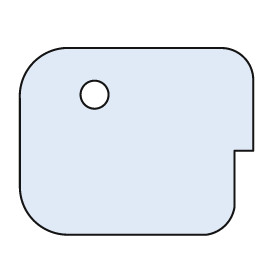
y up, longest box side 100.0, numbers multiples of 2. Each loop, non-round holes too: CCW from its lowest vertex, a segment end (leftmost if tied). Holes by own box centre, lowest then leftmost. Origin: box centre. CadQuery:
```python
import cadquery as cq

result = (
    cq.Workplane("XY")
    .moveTo(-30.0, -40.0)
    .lineTo(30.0, -40.0)
    .threePointArc((38.0, -36.0), (42.0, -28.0))
    .lineTo(42.0, -4.0)
    .lineTo(50.0, -4.0)
    .lineTo(50.0, 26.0)
    .threePointArc((46.0, 36.0), (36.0, 40.0))
    .lineTo(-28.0, 40.0)
    .threePointArc((-44.0, 34.0), (-50.0, 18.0))
    .lineTo(-50.0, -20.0)
    .threePointArc((-44.0, -34.0), (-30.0, -40.0))
    .close()
    .moveTo(-18.0, 20.0)
    .circle(6.0)
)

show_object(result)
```